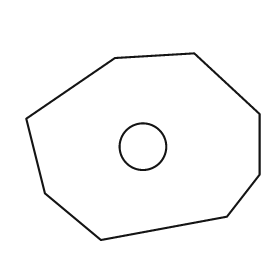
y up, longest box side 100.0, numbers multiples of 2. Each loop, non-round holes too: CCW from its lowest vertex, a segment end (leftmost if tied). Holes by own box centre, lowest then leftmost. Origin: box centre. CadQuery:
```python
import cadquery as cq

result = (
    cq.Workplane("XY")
    .moveTo(-18.0, -40.0)
    .lineTo(36.0, -30.0)
    .lineTo(50.0, -12.0)
    .lineTo(50.0, 14.0)
    .lineTo(22.0, 40.0)
    .lineTo(-12.0, 38.0)
    .lineTo(-50.0, 12.0)
    .lineTo(-42.0, -20.0)
    .close()
    .moveTo(0.0, 0.0)
    .circle(10.0)
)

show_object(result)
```